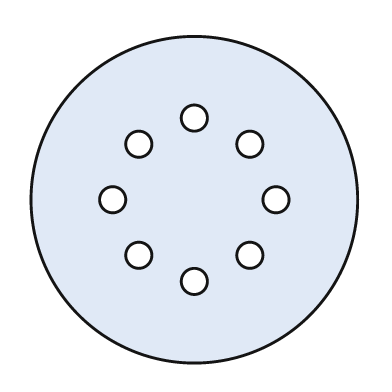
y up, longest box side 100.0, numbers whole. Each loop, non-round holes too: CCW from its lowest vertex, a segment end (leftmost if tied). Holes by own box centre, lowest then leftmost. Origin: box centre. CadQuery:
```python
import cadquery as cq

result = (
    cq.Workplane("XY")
    .moveTo(0.0, 0.0)
    .circle(50.0)
    .moveTo(0.0, -25.0)
    .circle(4.0)
    .moveTo(-17.0, -17.0)
    .circle(4.0)
    .moveTo(17.0, -17.0)
    .circle(4.0)
    .moveTo(-25.0, 0.0)
    .circle(4.0)
    .moveTo(25.0, 0.0)
    .circle(4.0)
    .moveTo(-17.0, 17.0)
    .circle(4.0)
    .moveTo(17.0, 17.0)
    .circle(4.0)
    .moveTo(0.0, 25.0)
    .circle(4.0)
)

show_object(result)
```